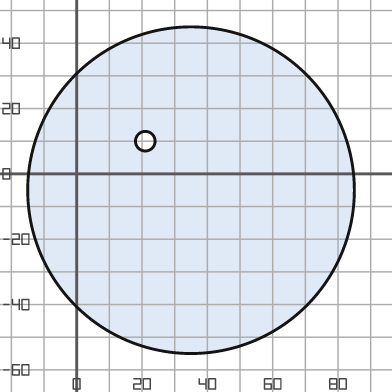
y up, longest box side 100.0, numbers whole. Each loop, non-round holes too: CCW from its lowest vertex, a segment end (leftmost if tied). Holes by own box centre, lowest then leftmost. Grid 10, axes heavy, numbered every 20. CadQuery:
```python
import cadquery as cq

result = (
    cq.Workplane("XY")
    .moveTo(35.0, -5.0)
    .circle(50.0)
    .moveTo(21.0, 10.0)
    .circle(3.0)
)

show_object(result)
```